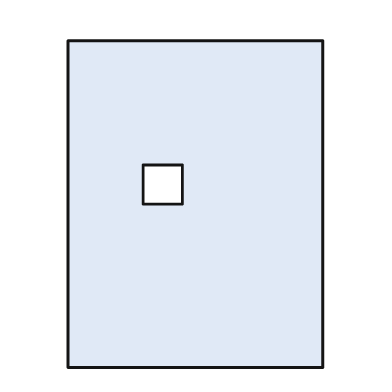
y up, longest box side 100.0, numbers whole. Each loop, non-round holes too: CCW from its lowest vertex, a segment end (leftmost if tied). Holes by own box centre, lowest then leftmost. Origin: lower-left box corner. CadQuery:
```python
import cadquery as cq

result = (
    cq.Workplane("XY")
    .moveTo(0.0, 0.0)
    .lineTo(78.0, 0.0)
    .lineTo(78.0, 100.0)
    .lineTo(0.0, 100.0)
    .close()
    .moveTo(23.0, 50.0)
    .lineTo(35.0, 50.0)
    .lineTo(35.0, 62.0)
    .lineTo(23.0, 62.0)
    .close()
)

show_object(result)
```